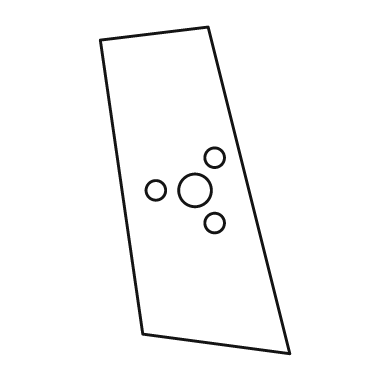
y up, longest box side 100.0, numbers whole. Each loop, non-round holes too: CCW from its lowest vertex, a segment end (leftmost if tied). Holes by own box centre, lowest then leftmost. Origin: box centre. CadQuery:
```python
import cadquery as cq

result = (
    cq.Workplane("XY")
    .moveTo(29.0, -50.0)
    .lineTo(4.0, 50.0)
    .lineTo(-29.0, 46.0)
    .lineTo(-16.0, -44.0)
    .close()
    .moveTo(6.0, -10.0)
    .circle(3.0)
    .moveTo(-12.0, 0.0)
    .circle(3.0)
    .moveTo(0.0, 0.0)
    .circle(5.0)
    .moveTo(6.0, 10.0)
    .circle(3.0)
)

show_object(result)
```